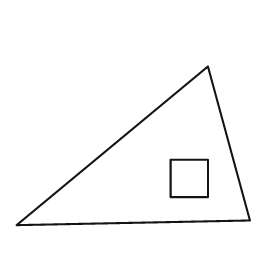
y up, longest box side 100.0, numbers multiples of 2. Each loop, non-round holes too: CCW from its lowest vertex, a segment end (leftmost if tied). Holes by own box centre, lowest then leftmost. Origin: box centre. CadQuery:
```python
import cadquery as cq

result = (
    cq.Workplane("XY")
    .moveTo(-50.0, -34.0)
    .lineTo(50.0, -32.0)
    .lineTo(32.0, 34.0)
    .close()
    .moveTo(16.0, -22.0)
    .lineTo(32.0, -22.0)
    .lineTo(32.0, -6.0)
    .lineTo(16.0, -6.0)
    .close()
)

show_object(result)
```